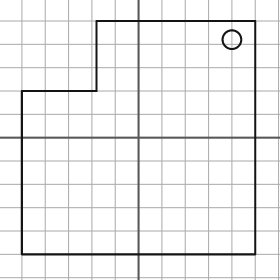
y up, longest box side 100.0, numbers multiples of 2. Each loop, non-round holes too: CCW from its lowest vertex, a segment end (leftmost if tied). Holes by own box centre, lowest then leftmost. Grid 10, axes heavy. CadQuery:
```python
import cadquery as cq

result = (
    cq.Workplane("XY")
    .moveTo(-50.0, -50.0)
    .lineTo(50.0, -50.0)
    .lineTo(50.0, 50.0)
    .lineTo(-18.0, 50.0)
    .lineTo(-18.0, 20.0)
    .lineTo(-50.0, 20.0)
    .close()
    .moveTo(40.0, 42.0)
    .circle(4.0)
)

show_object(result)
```